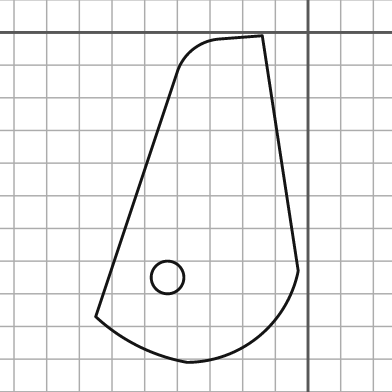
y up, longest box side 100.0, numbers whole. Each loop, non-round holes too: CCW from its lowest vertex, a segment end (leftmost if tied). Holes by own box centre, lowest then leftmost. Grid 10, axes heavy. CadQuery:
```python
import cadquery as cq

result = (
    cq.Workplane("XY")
    .moveTo(-37.0, -101.0)
    .threePointArc((-15.0, -93.0), (-3.0, -73.0))
    .lineTo(-14.0, -1.0)
    .lineTo(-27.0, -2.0)
    .threePointArc((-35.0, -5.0), (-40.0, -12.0))
    .lineTo(-65.0, -87.0)
    .threePointArc((-52.0, -96.0), (-37.0, -101.0))
    .close()
    .moveTo(-43.0, -75.0)
    .circle(5.0)
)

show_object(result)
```